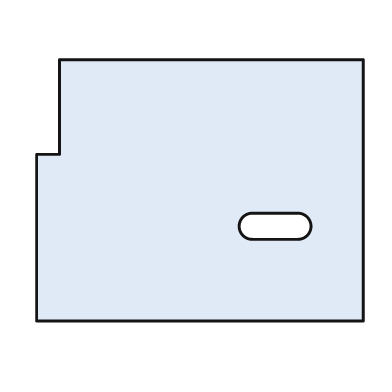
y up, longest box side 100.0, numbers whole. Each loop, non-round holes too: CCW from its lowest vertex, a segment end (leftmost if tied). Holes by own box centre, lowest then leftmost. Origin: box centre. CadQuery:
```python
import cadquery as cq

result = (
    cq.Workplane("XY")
    .moveTo(-50.0, -40.0)
    .lineTo(50.0, -40.0)
    .lineTo(50.0, 40.0)
    .lineTo(-43.0, 40.0)
    .lineTo(-43.0, 11.0)
    .lineTo(-50.0, 11.0)
    .close()
    .moveTo(16.0, -15.0)
    .lineTo(30.0, -15.0)
    .threePointArc((34.0, -11.0), (30.0, -7.0))
    .lineTo(16.0, -7.0)
    .threePointArc((12.0, -11.0), (16.0, -15.0))
    .close()
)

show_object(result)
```